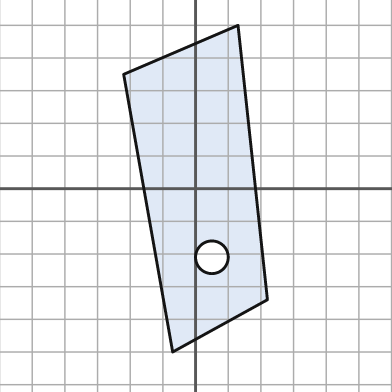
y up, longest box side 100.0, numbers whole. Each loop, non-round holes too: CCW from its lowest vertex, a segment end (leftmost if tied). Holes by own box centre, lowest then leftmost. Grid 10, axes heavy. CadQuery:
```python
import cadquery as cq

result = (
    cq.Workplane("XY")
    .moveTo(-7.0, -50.0)
    .lineTo(22.0, -34.0)
    .lineTo(13.0, 50.0)
    .lineTo(-22.0, 35.0)
    .close()
    .moveTo(5.0, -21.0)
    .circle(5.0)
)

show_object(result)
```